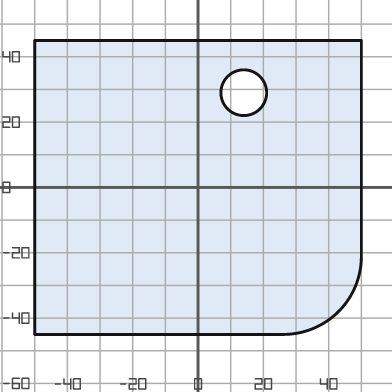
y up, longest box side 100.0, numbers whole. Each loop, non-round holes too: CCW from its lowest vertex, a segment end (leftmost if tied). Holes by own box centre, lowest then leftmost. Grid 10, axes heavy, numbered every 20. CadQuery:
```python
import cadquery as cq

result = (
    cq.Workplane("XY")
    .moveTo(-50.0, -45.0)
    .lineTo(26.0, -45.0)
    .threePointArc((43.0, -38.0), (50.0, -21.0))
    .lineTo(50.0, 45.0)
    .lineTo(-50.0, 45.0)
    .close()
    .moveTo(14.0, 29.0)
    .circle(7.0)
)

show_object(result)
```